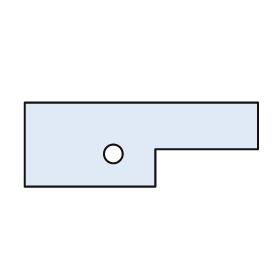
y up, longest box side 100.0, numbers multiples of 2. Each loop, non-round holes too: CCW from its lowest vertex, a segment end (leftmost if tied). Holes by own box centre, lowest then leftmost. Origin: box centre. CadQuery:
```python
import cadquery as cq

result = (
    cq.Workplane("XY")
    .moveTo(-50.0, -18.0)
    .lineTo(6.0, -18.0)
    .lineTo(6.0, -2.0)
    .lineTo(50.0, -2.0)
    .lineTo(50.0, 18.0)
    .lineTo(-50.0, 18.0)
    .close()
    .moveTo(-12.0, -4.0)
    .circle(4.0)
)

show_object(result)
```